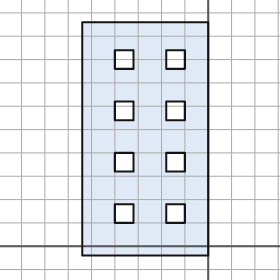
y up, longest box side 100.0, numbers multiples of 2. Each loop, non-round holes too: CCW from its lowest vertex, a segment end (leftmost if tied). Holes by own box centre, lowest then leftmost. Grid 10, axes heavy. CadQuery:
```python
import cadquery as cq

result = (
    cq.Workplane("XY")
    .moveTo(-54.0, -4.0)
    .lineTo(0.0, -4.0)
    .lineTo(0.0, 96.0)
    .lineTo(-54.0, 96.0)
    .close()
    .moveTo(-40.0, 10.0)
    .lineTo(-32.0, 10.0)
    .lineTo(-32.0, 18.0)
    .lineTo(-40.0, 18.0)
    .close()
    .moveTo(-18.0, 10.0)
    .lineTo(-10.0, 10.0)
    .lineTo(-10.0, 18.0)
    .lineTo(-18.0, 18.0)
    .close()
    .moveTo(-40.0, 32.0)
    .lineTo(-32.0, 32.0)
    .lineTo(-32.0, 40.0)
    .lineTo(-40.0, 40.0)
    .close()
    .moveTo(-18.0, 32.0)
    .lineTo(-10.0, 32.0)
    .lineTo(-10.0, 40.0)
    .lineTo(-18.0, 40.0)
    .close()
    .moveTo(-40.0, 54.0)
    .lineTo(-32.0, 54.0)
    .lineTo(-32.0, 62.0)
    .lineTo(-40.0, 62.0)
    .close()
    .moveTo(-18.0, 54.0)
    .lineTo(-10.0, 54.0)
    .lineTo(-10.0, 62.0)
    .lineTo(-18.0, 62.0)
    .close()
    .moveTo(-40.0, 76.0)
    .lineTo(-32.0, 76.0)
    .lineTo(-32.0, 84.0)
    .lineTo(-40.0, 84.0)
    .close()
    .moveTo(-18.0, 76.0)
    .lineTo(-10.0, 76.0)
    .lineTo(-10.0, 84.0)
    .lineTo(-18.0, 84.0)
    .close()
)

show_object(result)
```